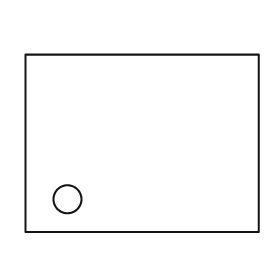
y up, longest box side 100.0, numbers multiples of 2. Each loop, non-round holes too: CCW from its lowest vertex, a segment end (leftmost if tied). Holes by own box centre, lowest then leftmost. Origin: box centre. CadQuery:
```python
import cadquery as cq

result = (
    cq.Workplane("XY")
    .moveTo(-50.0, -38.0)
    .lineTo(50.0, -38.0)
    .lineTo(50.0, 38.0)
    .lineTo(-50.0, 38.0)
    .close()
    .moveTo(-32.0, -24.0)
    .circle(6.0)
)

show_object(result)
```